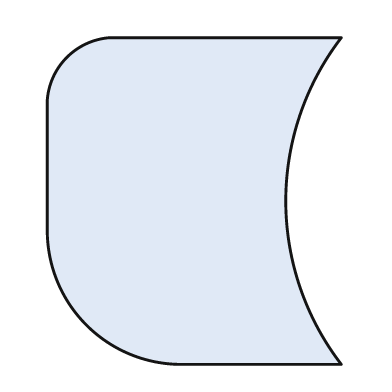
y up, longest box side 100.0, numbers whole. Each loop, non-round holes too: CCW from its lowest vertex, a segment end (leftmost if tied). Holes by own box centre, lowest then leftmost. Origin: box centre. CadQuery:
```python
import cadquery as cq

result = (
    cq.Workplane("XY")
    .moveTo(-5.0, -50.0)
    .lineTo(45.0, -50.0)
    .threePointArc((28.0, 0.0), (45.0, 50.0))
    .lineTo(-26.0, 50.0)
    .threePointArc((-39.0, 44.0), (-45.0, 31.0))
    .lineTo(-45.0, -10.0)
    .threePointArc((-33.0, -38.0), (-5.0, -50.0))
    .close()
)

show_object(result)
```